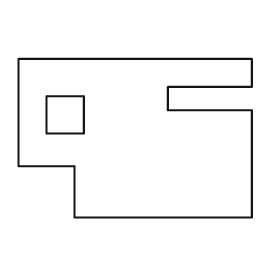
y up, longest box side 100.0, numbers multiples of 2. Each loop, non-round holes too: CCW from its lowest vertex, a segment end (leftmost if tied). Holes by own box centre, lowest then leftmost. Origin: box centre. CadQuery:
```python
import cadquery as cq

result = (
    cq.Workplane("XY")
    .moveTo(-26.0, -34.0)
    .lineTo(50.0, -34.0)
    .lineTo(50.0, 12.0)
    .lineTo(14.0, 12.0)
    .lineTo(14.0, 22.0)
    .lineTo(50.0, 22.0)
    .lineTo(50.0, 34.0)
    .lineTo(-50.0, 34.0)
    .lineTo(-50.0, -12.0)
    .lineTo(-26.0, -12.0)
    .close()
    .moveTo(-38.0, 2.0)
    .lineTo(-22.0, 2.0)
    .lineTo(-22.0, 18.0)
    .lineTo(-38.0, 18.0)
    .close()
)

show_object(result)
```